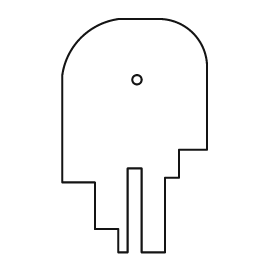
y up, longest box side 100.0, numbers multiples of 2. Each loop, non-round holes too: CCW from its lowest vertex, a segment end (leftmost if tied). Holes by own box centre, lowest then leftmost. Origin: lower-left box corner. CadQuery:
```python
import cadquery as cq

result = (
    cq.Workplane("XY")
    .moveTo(24.0, 0.0)
    .lineTo(28.0, 0.0)
    .lineTo(28.0, 36.0)
    .lineTo(34.0, 36.0)
    .lineTo(34.0, 0.0)
    .lineTo(44.0, 0.0)
    .lineTo(44.0, 32.0)
    .lineTo(50.0, 32.0)
    .lineTo(50.0, 44.0)
    .lineTo(62.0, 44.0)
    .lineTo(62.0, 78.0)
    .threePointArc((56.0, 94.0), (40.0, 100.0))
    .lineTo(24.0, 100.0)
    .threePointArc((8.0, 92.0), (0.0, 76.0))
    .lineTo(0.0, 30.0)
    .lineTo(14.0, 30.0)
    .lineTo(14.0, 10.0)
    .lineTo(24.0, 10.0)
    .close()
    .moveTo(32.0, 74.0)
    .circle(2.0)
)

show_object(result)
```